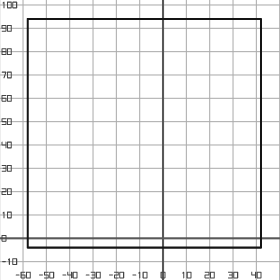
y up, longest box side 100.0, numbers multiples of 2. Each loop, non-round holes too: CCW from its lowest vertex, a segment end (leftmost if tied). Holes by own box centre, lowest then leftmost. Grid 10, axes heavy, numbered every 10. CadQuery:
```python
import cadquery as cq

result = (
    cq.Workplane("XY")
    .moveTo(-58.0, -4.0)
    .lineTo(42.0, -4.0)
    .lineTo(42.0, 94.0)
    .lineTo(-58.0, 94.0)
    .close()
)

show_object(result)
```